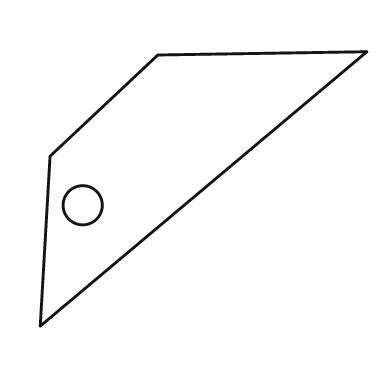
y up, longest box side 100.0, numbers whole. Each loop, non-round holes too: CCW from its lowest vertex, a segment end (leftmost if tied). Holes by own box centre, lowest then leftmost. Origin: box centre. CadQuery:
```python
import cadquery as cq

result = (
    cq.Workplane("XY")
    .moveTo(-50.0, -42.0)
    .lineTo(50.0, 42.0)
    .lineTo(-14.0, 41.0)
    .lineTo(-47.0, 10.0)
    .close()
    .moveTo(-37.0, -5.0)
    .circle(6.0)
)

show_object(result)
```